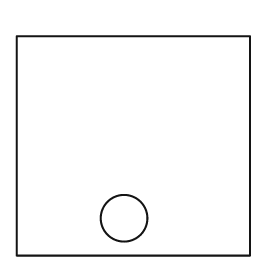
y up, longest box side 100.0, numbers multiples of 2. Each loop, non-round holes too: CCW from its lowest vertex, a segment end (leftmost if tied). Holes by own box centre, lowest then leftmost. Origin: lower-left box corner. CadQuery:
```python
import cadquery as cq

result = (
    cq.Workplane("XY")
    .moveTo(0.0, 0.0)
    .lineTo(100.0, 0.0)
    .lineTo(100.0, 94.0)
    .lineTo(0.0, 94.0)
    .close()
    .moveTo(46.0, 16.0)
    .circle(10.0)
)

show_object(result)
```